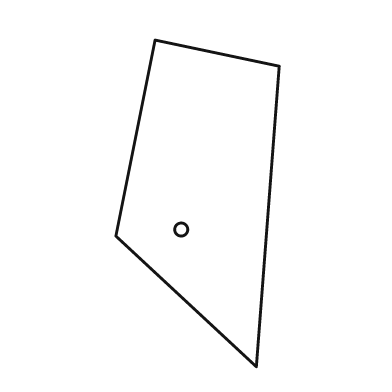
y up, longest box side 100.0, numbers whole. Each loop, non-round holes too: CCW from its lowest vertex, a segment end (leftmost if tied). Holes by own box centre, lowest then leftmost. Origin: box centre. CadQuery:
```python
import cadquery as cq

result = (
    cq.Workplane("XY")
    .moveTo(18.0, -50.0)
    .lineTo(25.0, 42.0)
    .lineTo(-13.0, 50.0)
    .lineTo(-25.0, -10.0)
    .close()
    .moveTo(-5.0, -8.0)
    .circle(2.0)
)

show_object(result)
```